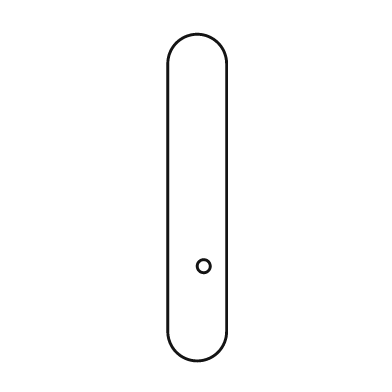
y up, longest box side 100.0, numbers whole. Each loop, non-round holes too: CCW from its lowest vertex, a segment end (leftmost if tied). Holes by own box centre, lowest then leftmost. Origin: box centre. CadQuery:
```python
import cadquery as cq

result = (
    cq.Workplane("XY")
    .moveTo(-9.0, -41.0)
    .threePointArc((0.0, -50.0), (9.0, -41.0))
    .lineTo(9.0, 41.0)
    .threePointArc((0.0, 50.0), (-9.0, 41.0))
    .close()
    .moveTo(2.0, -21.0)
    .circle(2.0)
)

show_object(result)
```